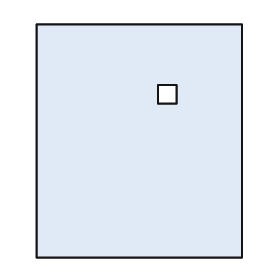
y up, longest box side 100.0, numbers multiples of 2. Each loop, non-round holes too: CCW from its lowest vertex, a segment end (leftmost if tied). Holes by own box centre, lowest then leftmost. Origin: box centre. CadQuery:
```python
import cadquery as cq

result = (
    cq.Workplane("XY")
    .moveTo(-44.0, -50.0)
    .lineTo(44.0, -50.0)
    .lineTo(44.0, 50.0)
    .lineTo(-44.0, 50.0)
    .close()
    .moveTo(8.0, 16.0)
    .lineTo(16.0, 16.0)
    .lineTo(16.0, 24.0)
    .lineTo(8.0, 24.0)
    .close()
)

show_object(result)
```